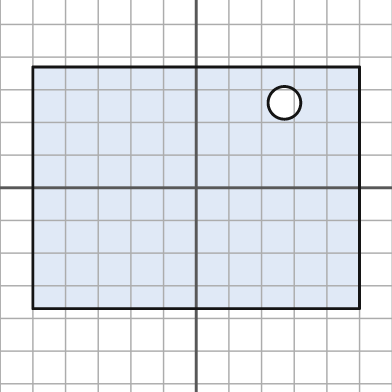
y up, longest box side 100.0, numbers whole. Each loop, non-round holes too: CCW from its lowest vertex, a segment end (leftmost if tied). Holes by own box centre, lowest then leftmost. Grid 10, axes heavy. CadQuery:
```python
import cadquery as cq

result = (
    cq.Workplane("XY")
    .moveTo(-50.0, -37.0)
    .lineTo(50.0, -37.0)
    .lineTo(50.0, 37.0)
    .lineTo(-50.0, 37.0)
    .close()
    .moveTo(27.0, 26.0)
    .circle(5.0)
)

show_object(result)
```